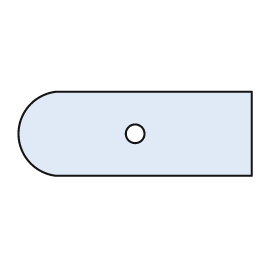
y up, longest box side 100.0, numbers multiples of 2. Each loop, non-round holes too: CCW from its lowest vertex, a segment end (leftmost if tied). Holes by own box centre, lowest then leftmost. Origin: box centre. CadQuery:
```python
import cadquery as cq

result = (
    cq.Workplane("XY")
    .moveTo(-34.0, -18.0)
    .lineTo(50.0, -18.0)
    .lineTo(50.0, 18.0)
    .lineTo(-34.0, 18.0)
    .threePointArc((-50.0, 0.0), (-34.0, -18.0))
    .close()
    .moveTo(0.0, 0.0)
    .circle(4.0)
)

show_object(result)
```